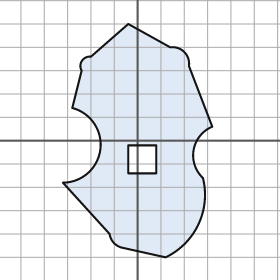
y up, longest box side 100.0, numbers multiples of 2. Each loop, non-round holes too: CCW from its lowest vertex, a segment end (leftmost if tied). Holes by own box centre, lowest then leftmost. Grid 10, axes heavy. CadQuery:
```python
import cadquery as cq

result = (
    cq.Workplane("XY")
    .moveTo(12.0, -50.0)
    .threePointArc((26.0, -36.0), (28.0, -16.0))
    .threePointArc((24.0, -4.0), (32.0, 6.0))
    .lineTo(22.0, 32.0)
    .threePointArc((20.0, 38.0), (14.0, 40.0))
    .lineTo(-4.0, 50.0)
    .lineTo(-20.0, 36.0)
    .threePointArc((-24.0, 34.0), (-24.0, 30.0))
    .lineTo(-28.0, 14.0)
    .threePointArc((-16.0, -4.0), (-32.0, -18.0))
    .lineTo(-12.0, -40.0)
    .threePointArc((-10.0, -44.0), (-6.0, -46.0))
    .close()
    .moveTo(-4.0, -14.0)
    .lineTo(8.0, -14.0)
    .lineTo(8.0, -2.0)
    .lineTo(-4.0, -2.0)
    .close()
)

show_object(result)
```